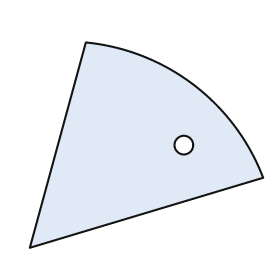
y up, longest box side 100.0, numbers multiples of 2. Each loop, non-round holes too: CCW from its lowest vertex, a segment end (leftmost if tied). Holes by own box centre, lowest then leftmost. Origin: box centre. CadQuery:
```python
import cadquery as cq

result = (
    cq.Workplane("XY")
    .moveTo(-50.0, -44.0)
    .lineTo(50.0, -14.0)
    .threePointArc((20.0, 26.0), (-26.0, 44.0))
    .close()
    .moveTo(16.0, 0.0)
    .circle(4.0)
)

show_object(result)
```